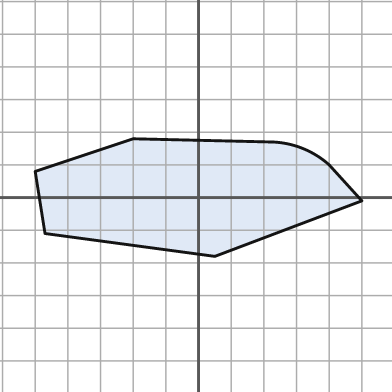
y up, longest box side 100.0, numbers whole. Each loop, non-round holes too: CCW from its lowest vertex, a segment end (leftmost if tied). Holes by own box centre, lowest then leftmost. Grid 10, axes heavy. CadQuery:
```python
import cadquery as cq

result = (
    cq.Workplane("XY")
    .moveTo(5.0, -18.0)
    .lineTo(50.0, -1.0)
    .lineTo(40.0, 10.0)
    .threePointArc((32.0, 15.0), (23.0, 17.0))
    .lineTo(-20.0, 18.0)
    .lineTo(-50.0, 8.0)
    .lineTo(-47.0, -11.0)
    .close()
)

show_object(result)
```